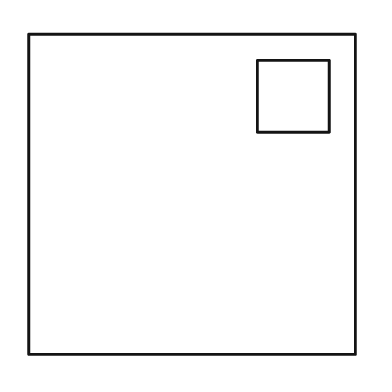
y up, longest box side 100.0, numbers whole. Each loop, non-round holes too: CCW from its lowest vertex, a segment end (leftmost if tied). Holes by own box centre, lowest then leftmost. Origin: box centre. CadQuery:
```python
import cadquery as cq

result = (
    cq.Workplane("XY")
    .moveTo(-50.0, -49.0)
    .lineTo(50.0, -49.0)
    .lineTo(50.0, 49.0)
    .lineTo(-50.0, 49.0)
    .close()
    .moveTo(20.0, 19.0)
    .lineTo(42.0, 19.0)
    .lineTo(42.0, 41.0)
    .lineTo(20.0, 41.0)
    .close()
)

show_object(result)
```